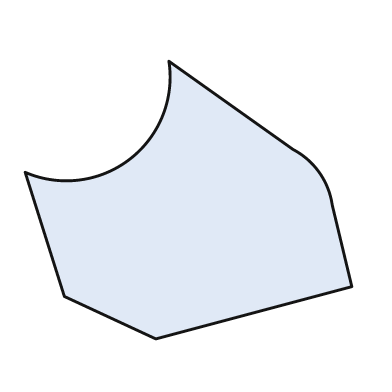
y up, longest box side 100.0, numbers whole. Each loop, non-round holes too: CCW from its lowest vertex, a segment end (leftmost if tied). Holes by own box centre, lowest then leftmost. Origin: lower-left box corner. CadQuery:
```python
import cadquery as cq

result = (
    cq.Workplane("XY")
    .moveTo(40.0, 0.0)
    .lineTo(100.0, 16.0)
    .lineTo(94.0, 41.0)
    .threePointArc((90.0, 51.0), (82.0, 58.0))
    .lineTo(44.0, 85.0)
    .threePointArc((32.0, 55.0), (0.0, 51.0))
    .lineTo(12.0, 13.0)
    .close()
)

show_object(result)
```